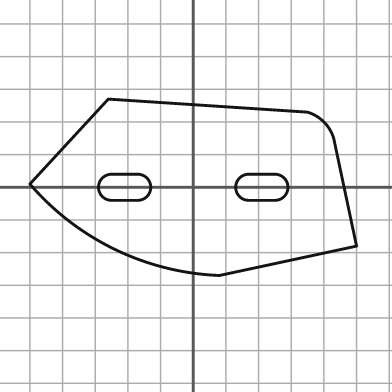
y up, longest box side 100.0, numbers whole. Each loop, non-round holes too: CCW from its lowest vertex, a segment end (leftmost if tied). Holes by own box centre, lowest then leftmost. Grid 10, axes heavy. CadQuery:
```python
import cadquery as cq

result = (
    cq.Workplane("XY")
    .moveTo(8.0, -27.0)
    .lineTo(50.0, -18.0)
    .lineTo(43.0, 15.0)
    .threePointArc((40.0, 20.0), (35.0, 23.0))
    .lineTo(-26.0, 27.0)
    .lineTo(-50.0, 1.0)
    .threePointArc((-24.0, -19.0), (8.0, -27.0))
    .close()
    .moveTo(-25.0, -4.0)
    .lineTo(-17.0, -4.0)
    .threePointArc((-13.0, 0.0), (-17.0, 4.0))
    .lineTo(-25.0, 4.0)
    .threePointArc((-29.0, 0.0), (-25.0, -4.0))
    .close()
    .moveTo(17.0, -4.0)
    .lineTo(25.0, -4.0)
    .threePointArc((29.0, 0.0), (25.0, 4.0))
    .lineTo(17.0, 4.0)
    .threePointArc((13.0, 0.0), (17.0, -4.0))
    .close()
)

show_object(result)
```